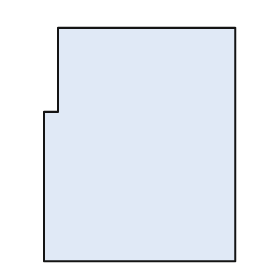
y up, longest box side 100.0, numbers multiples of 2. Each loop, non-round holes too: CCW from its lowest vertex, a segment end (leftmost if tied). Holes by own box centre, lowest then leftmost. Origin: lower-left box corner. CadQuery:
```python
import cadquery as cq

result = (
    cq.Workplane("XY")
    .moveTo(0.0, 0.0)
    .lineTo(82.0, 0.0)
    .lineTo(82.0, 100.0)
    .lineTo(6.0, 100.0)
    .lineTo(6.0, 64.0)
    .lineTo(0.0, 64.0)
    .close()
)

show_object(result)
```